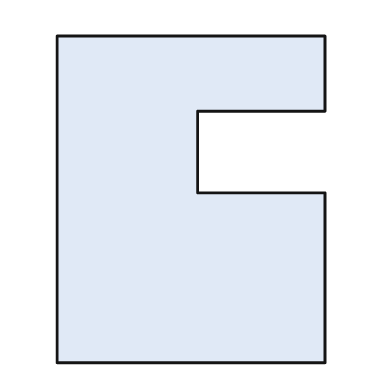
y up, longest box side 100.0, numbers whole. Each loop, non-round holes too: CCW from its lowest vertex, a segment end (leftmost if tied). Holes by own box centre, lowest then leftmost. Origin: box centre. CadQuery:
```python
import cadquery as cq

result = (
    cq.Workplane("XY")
    .moveTo(-41.0, -50.0)
    .lineTo(41.0, -50.0)
    .lineTo(41.0, 2.0)
    .lineTo(2.0, 2.0)
    .lineTo(2.0, 27.0)
    .lineTo(41.0, 27.0)
    .lineTo(41.0, 50.0)
    .lineTo(-41.0, 50.0)
    .close()
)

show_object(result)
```